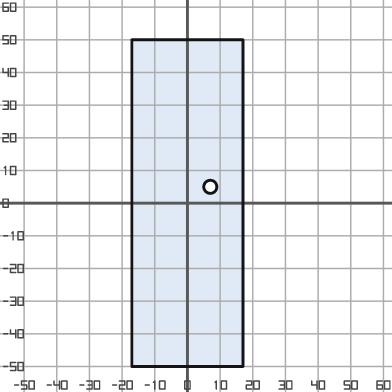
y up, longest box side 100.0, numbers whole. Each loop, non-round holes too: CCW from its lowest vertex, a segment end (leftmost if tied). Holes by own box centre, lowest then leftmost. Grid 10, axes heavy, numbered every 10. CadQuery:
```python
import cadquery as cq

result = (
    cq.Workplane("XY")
    .moveTo(-17.0, -50.0)
    .lineTo(17.0, -50.0)
    .lineTo(17.0, 50.0)
    .lineTo(-17.0, 50.0)
    .close()
    .moveTo(7.0, 5.0)
    .circle(2.0)
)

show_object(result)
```